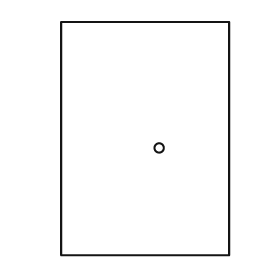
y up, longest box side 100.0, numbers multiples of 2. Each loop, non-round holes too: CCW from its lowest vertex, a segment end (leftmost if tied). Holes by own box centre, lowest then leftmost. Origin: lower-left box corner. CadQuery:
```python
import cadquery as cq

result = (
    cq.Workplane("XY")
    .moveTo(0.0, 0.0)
    .lineTo(72.0, 0.0)
    .lineTo(72.0, 100.0)
    .lineTo(0.0, 100.0)
    .close()
    .moveTo(42.0, 46.0)
    .circle(2.0)
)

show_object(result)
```